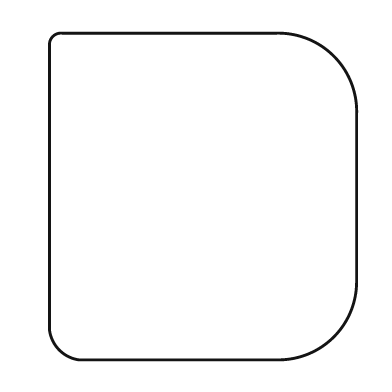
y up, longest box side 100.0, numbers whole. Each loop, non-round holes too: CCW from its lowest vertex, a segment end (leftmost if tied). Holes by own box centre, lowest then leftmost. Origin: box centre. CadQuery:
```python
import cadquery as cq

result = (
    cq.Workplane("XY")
    .moveTo(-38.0, -50.0)
    .lineTo(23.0, -50.0)
    .threePointArc((40.0, -43.0), (47.0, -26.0))
    .lineTo(47.0, 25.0)
    .threePointArc((40.0, 43.0), (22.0, 50.0))
    .lineTo(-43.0, 50.0)
    .threePointArc((-46.0, 49.0), (-47.0, 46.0))
    .lineTo(-47.0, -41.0)
    .threePointArc((-44.0, -47.0), (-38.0, -50.0))
    .close()
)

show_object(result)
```